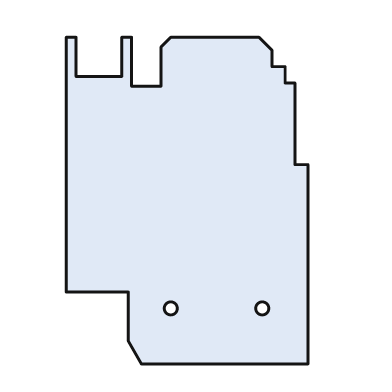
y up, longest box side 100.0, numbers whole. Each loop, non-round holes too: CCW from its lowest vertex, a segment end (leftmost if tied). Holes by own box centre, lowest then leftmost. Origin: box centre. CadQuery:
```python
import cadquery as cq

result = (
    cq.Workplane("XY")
    .moveTo(-14.0, -50.0)
    .lineTo(37.0, -50.0)
    .lineTo(37.0, 11.0)
    .lineTo(33.0, 11.0)
    .lineTo(33.0, 36.0)
    .lineTo(30.0, 36.0)
    .lineTo(30.0, 41.0)
    .lineTo(26.0, 41.0)
    .lineTo(26.0, 46.0)
    .lineTo(22.0, 50.0)
    .lineTo(-5.0, 50.0)
    .lineTo(-8.0, 47.0)
    .lineTo(-8.0, 35.0)
    .lineTo(-17.0, 35.0)
    .lineTo(-17.0, 50.0)
    .lineTo(-20.0, 50.0)
    .lineTo(-20.0, 38.0)
    .lineTo(-34.0, 38.0)
    .lineTo(-34.0, 50.0)
    .lineTo(-37.0, 50.0)
    .lineTo(-37.0, -28.0)
    .lineTo(-18.0, -28.0)
    .lineTo(-18.0, -43.0)
    .close()
    .moveTo(-5.0, -33.0)
    .circle(2.0)
    .moveTo(23.0, -33.0)
    .circle(2.0)
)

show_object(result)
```